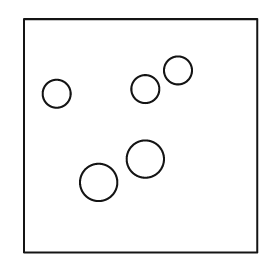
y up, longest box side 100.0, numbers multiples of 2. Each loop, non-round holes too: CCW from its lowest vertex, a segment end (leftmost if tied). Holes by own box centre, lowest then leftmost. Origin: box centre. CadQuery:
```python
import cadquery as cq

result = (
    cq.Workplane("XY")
    .moveTo(-50.0, -50.0)
    .lineTo(50.0, -50.0)
    .lineTo(50.0, 50.0)
    .lineTo(-50.0, 50.0)
    .close()
    .moveTo(-18.0, -20.0)
    .circle(8.0)
    .moveTo(2.0, -10.0)
    .circle(8.0)
    .moveTo(-36.0, 18.0)
    .circle(6.0)
    .moveTo(2.0, 20.0)
    .circle(6.0)
    .moveTo(16.0, 28.0)
    .circle(6.0)
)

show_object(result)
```